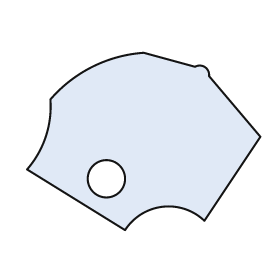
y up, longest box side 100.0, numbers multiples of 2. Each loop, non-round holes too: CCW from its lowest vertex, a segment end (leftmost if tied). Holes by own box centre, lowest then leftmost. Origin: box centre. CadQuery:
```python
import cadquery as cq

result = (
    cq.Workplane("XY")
    .moveTo(-8.0, -38.0)
    .threePointArc((8.0, -28.0), (26.0, -34.0))
    .lineTo(50.0, 2.0)
    .lineTo(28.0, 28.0)
    .threePointArc((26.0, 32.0), (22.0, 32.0))
    .lineTo(0.0, 38.0)
    .threePointArc((-22.0, 32.0), (-40.0, 18.0))
    .threePointArc((-42.0, 2.0), (-50.0, -12.0))
    .close()
    .moveTo(-16.0, -16.0)
    .circle(8.0)
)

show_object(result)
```